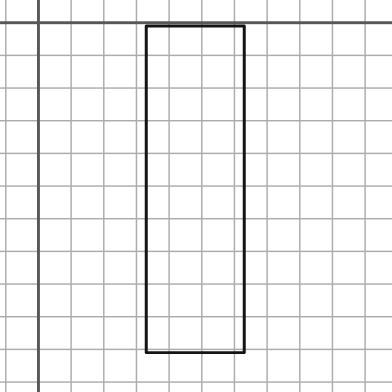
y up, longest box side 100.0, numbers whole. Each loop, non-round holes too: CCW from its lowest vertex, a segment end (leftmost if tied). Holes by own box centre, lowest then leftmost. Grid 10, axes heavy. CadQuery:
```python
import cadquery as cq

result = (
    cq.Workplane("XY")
    .moveTo(33.0, -101.0)
    .lineTo(63.0, -101.0)
    .lineTo(63.0, -1.0)
    .lineTo(33.0, -1.0)
    .close()
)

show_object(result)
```